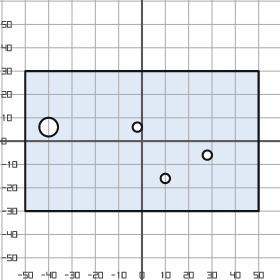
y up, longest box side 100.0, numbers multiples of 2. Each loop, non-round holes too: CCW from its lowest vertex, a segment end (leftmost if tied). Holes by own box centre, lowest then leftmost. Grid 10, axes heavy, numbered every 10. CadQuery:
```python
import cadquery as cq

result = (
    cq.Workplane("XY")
    .moveTo(-50.0, -30.0)
    .lineTo(50.0, -30.0)
    .lineTo(50.0, 30.0)
    .lineTo(-50.0, 30.0)
    .close()
    .moveTo(10.0, -16.0)
    .circle(2.0)
    .moveTo(28.0, -6.0)
    .circle(2.0)
    .moveTo(-40.0, 6.0)
    .circle(4.0)
    .moveTo(-2.0, 6.0)
    .circle(2.0)
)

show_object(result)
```